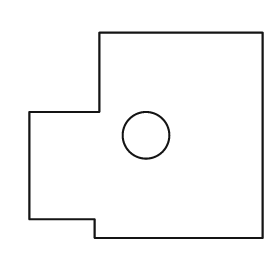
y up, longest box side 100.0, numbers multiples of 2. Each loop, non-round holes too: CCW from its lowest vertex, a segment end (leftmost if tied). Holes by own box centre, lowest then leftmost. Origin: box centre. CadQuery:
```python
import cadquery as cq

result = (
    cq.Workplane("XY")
    .moveTo(-22.0, -44.0)
    .lineTo(50.0, -44.0)
    .lineTo(50.0, 44.0)
    .lineTo(-20.0, 44.0)
    .lineTo(-20.0, 10.0)
    .lineTo(-50.0, 10.0)
    .lineTo(-50.0, -36.0)
    .lineTo(-22.0, -36.0)
    .close()
    .moveTo(0.0, 0.0)
    .circle(10.0)
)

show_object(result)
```